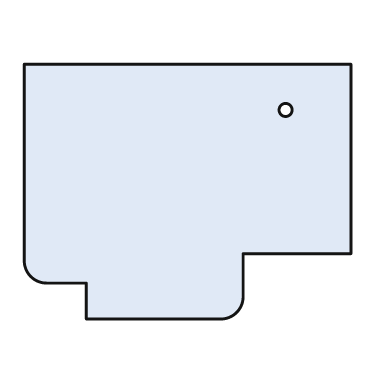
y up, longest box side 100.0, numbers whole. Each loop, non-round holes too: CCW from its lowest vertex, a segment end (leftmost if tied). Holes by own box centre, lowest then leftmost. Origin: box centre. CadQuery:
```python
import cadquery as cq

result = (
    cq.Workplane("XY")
    .moveTo(-31.0, -39.0)
    .lineTo(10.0, -39.0)
    .threePointArc((15.0, -37.0), (17.0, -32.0))
    .lineTo(17.0, -19.0)
    .lineTo(50.0, -19.0)
    .lineTo(50.0, 39.0)
    .lineTo(-50.0, 39.0)
    .lineTo(-50.0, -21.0)
    .threePointArc((-48.0, -26.0), (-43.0, -28.0))
    .lineTo(-31.0, -28.0)
    .close()
    .moveTo(30.0, 25.0)
    .circle(2.0)
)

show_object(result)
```